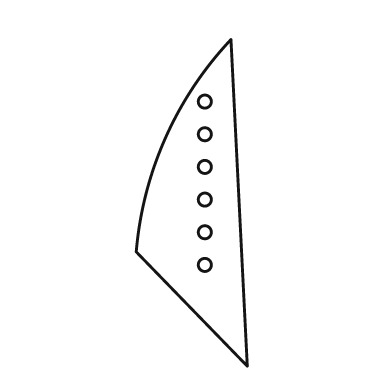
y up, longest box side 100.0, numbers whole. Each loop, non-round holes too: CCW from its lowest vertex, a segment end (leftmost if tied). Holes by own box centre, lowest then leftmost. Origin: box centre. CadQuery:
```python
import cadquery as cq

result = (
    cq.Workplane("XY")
    .moveTo(17.0, -50.0)
    .lineTo(12.0, 50.0)
    .threePointArc((-8.0, 20.0), (-17.0, -15.0))
    .close()
    .moveTo(4.0, -19.0)
    .circle(2.0)
    .moveTo(4.0, -9.0)
    .circle(2.0)
    .moveTo(4.0, 1.0)
    .circle(2.0)
    .moveTo(4.0, 11.0)
    .circle(2.0)
    .moveTo(4.0, 21.0)
    .circle(2.0)
    .moveTo(4.0, 31.0)
    .circle(2.0)
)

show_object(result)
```